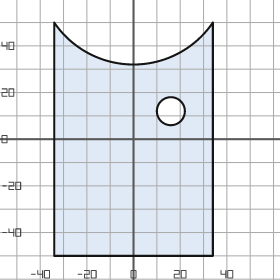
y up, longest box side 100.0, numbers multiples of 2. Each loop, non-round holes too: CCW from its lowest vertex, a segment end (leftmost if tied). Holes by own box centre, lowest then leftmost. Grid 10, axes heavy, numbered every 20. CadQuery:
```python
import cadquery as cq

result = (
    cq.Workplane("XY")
    .moveTo(-34.0, -50.0)
    .lineTo(34.0, -50.0)
    .lineTo(34.0, 50.0)
    .threePointArc((0.0, 32.0), (-34.0, 50.0))
    .close()
    .moveTo(16.0, 12.0)
    .circle(6.0)
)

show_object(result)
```